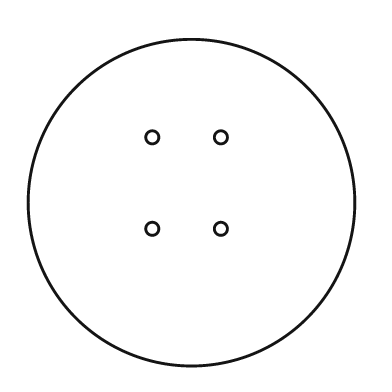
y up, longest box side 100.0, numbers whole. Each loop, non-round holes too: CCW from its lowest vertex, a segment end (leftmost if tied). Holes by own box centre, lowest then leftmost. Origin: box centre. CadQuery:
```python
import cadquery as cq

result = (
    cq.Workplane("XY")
    .moveTo(0.0, 0.0)
    .circle(50.0)
    .moveTo(-12.0, -8.0)
    .circle(2.0)
    .moveTo(9.0, -8.0)
    .circle(2.0)
    .moveTo(-12.0, 20.0)
    .circle(2.0)
    .moveTo(9.0, 20.0)
    .circle(2.0)
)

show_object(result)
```